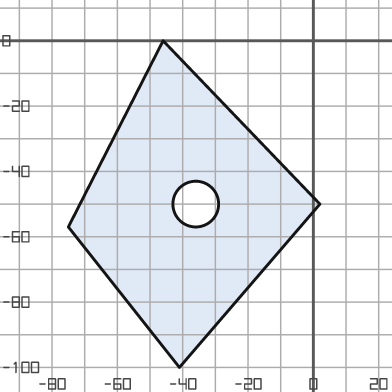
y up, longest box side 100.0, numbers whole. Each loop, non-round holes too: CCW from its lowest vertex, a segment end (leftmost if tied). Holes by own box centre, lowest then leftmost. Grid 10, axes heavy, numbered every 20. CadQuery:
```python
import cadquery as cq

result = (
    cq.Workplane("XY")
    .moveTo(-41.0, -100.0)
    .lineTo(2.0, -50.0)
    .lineTo(-46.0, 0.0)
    .lineTo(-75.0, -57.0)
    .close()
    .moveTo(-36.0, -50.0)
    .circle(7.0)
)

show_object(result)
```